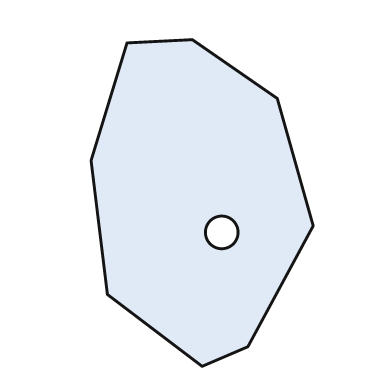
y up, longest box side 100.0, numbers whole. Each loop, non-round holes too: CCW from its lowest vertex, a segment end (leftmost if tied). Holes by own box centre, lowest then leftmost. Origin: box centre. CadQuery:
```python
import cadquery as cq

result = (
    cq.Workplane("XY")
    .moveTo(0.0, -50.0)
    .lineTo(14.0, -44.0)
    .lineTo(34.0, -7.0)
    .lineTo(23.0, 32.0)
    .lineTo(-3.0, 50.0)
    .lineTo(-23.0, 49.0)
    .lineTo(-34.0, 13.0)
    .lineTo(-29.0, -28.0)
    .close()
    .moveTo(6.0, -9.0)
    .circle(5.0)
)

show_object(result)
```